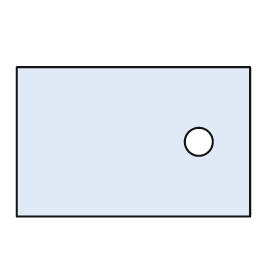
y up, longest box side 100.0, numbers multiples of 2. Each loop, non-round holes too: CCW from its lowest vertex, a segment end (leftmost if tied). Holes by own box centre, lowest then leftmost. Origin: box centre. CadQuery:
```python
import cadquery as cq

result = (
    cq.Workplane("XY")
    .moveTo(-50.0, -32.0)
    .lineTo(50.0, -32.0)
    .lineTo(50.0, 32.0)
    .lineTo(-50.0, 32.0)
    .close()
    .moveTo(28.0, 0.0)
    .circle(6.0)
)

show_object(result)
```